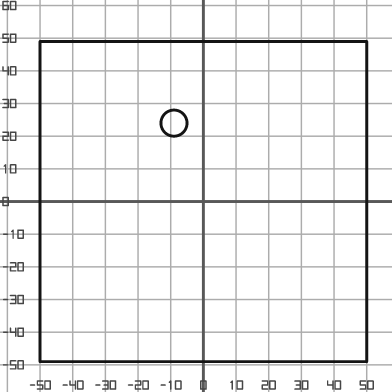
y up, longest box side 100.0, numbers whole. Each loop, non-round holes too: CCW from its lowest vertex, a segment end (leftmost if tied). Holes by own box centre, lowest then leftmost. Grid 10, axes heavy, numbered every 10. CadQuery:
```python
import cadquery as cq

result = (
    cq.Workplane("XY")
    .moveTo(-50.0, -49.0)
    .lineTo(50.0, -49.0)
    .lineTo(50.0, 49.0)
    .lineTo(-50.0, 49.0)
    .close()
    .moveTo(-9.0, 24.0)
    .circle(4.0)
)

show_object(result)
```